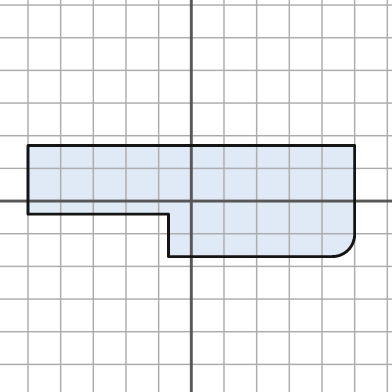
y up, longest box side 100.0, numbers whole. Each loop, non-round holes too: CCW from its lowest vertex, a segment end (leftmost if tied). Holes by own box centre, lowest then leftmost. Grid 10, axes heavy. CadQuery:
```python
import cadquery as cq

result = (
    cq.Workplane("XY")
    .moveTo(-7.0, -17.0)
    .lineTo(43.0, -17.0)
    .threePointArc((48.0, -15.0), (50.0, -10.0))
    .lineTo(50.0, 17.0)
    .lineTo(-50.0, 17.0)
    .lineTo(-50.0, -4.0)
    .lineTo(-7.0, -4.0)
    .close()
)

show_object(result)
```